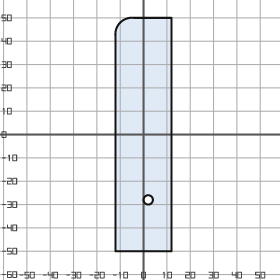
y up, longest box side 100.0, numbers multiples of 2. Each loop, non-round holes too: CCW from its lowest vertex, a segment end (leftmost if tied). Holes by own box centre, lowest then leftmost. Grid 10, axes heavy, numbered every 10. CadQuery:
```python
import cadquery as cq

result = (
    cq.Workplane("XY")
    .moveTo(-12.0, -50.0)
    .lineTo(12.0, -50.0)
    .lineTo(12.0, 50.0)
    .lineTo(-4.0, 50.0)
    .threePointArc((-10.0, 48.0), (-12.0, 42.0))
    .close()
    .moveTo(2.0, -28.0)
    .circle(2.0)
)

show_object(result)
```